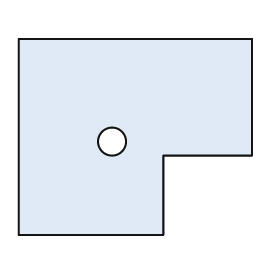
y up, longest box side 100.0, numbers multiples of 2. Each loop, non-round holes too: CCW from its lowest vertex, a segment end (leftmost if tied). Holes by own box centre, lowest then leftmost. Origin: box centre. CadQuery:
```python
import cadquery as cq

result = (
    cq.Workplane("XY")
    .moveTo(-50.0, -42.0)
    .lineTo(12.0, -42.0)
    .lineTo(12.0, -8.0)
    .lineTo(50.0, -8.0)
    .lineTo(50.0, 42.0)
    .lineTo(-50.0, 42.0)
    .close()
    .moveTo(-10.0, -2.0)
    .circle(6.0)
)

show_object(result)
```